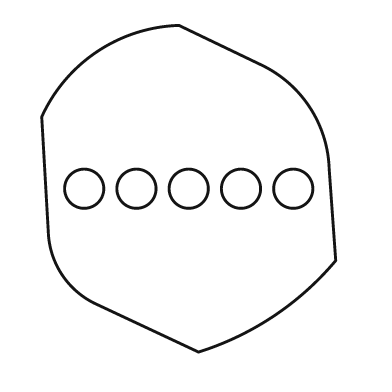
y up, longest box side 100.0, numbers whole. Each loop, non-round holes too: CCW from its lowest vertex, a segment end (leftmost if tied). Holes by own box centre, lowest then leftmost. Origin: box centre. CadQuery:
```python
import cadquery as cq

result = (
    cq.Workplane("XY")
    .moveTo(3.0, -50.0)
    .threePointArc((26.0, -39.0), (45.0, -22.0))
    .lineTo(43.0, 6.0)
    .threePointArc((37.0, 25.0), (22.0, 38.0))
    .lineTo(-3.0, 50.0)
    .threePointArc((-28.0, 42.0), (-45.0, 22.0))
    .lineTo(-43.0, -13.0)
    .threePointArc((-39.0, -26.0), (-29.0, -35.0))
    .close()
    .moveTo(-32.0, 0.0)
    .circle(6.0)
    .moveTo(-16.0, 0.0)
    .circle(6.0)
    .moveTo(0.0, 0.0)
    .circle(6.0)
    .moveTo(16.0, 0.0)
    .circle(6.0)
    .moveTo(32.0, 0.0)
    .circle(6.0)
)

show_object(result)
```